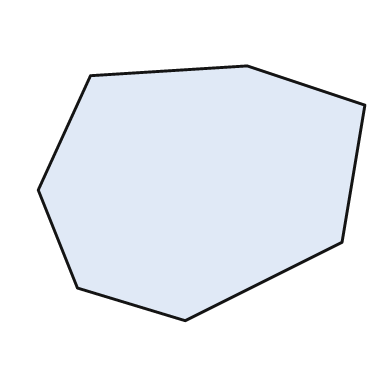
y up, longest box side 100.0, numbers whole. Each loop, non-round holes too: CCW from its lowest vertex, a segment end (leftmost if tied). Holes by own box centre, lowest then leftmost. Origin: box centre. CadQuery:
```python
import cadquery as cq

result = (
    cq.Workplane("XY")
    .moveTo(-5.0, -39.0)
    .lineTo(43.0, -15.0)
    .lineTo(50.0, 27.0)
    .lineTo(14.0, 39.0)
    .lineTo(-34.0, 36.0)
    .lineTo(-50.0, 1.0)
    .lineTo(-38.0, -29.0)
    .close()
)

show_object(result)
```